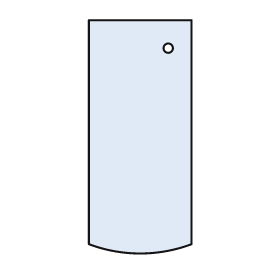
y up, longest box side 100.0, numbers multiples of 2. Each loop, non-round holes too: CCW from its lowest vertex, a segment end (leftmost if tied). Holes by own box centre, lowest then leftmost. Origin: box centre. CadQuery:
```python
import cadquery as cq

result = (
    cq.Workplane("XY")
    .moveTo(-22.0, -46.0)
    .threePointArc((0.0, -50.0), (22.0, -46.0))
    .lineTo(22.0, 50.0)
    .lineTo(-22.0, 50.0)
    .close()
    .moveTo(12.0, 38.0)
    .circle(2.0)
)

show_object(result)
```